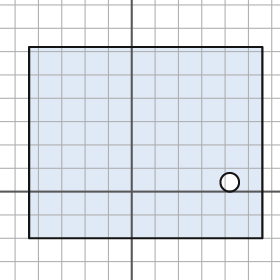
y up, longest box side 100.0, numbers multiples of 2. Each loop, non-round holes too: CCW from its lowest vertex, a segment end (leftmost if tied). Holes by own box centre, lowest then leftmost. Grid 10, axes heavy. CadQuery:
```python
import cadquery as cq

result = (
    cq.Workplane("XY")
    .moveTo(-44.0, -20.0)
    .lineTo(56.0, -20.0)
    .lineTo(56.0, 62.0)
    .lineTo(-44.0, 62.0)
    .close()
    .moveTo(42.0, 4.0)
    .circle(4.0)
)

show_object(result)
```